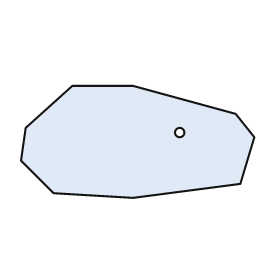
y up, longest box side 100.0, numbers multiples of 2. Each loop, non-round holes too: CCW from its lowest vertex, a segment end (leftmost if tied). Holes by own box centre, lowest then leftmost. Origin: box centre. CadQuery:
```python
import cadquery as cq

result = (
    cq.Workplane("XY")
    .moveTo(-2.0, -24.0)
    .lineTo(44.0, -18.0)
    .lineTo(50.0, 2.0)
    .lineTo(42.0, 12.0)
    .lineTo(-2.0, 24.0)
    .lineTo(-28.0, 24.0)
    .lineTo(-48.0, 6.0)
    .lineTo(-50.0, -8.0)
    .lineTo(-36.0, -22.0)
    .close()
    .moveTo(18.0, 4.0)
    .circle(2.0)
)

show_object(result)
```